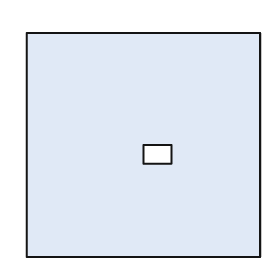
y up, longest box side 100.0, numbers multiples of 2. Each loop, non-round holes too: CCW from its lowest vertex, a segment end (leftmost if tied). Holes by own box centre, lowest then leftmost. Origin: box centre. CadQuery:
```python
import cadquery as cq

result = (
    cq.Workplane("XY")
    .moveTo(-50.0, -48.0)
    .lineTo(50.0, -48.0)
    .lineTo(50.0, 48.0)
    .lineTo(-50.0, 48.0)
    .close()
    .moveTo(0.0, -8.0)
    .lineTo(12.0, -8.0)
    .lineTo(12.0, 0.0)
    .lineTo(0.0, 0.0)
    .close()
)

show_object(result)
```